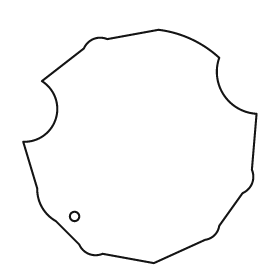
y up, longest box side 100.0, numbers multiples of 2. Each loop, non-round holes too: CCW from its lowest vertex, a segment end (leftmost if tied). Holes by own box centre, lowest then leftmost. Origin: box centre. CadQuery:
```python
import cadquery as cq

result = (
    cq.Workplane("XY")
    .moveTo(6.0, -50.0)
    .lineTo(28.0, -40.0)
    .threePointArc((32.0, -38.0), (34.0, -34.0))
    .lineTo(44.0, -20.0)
    .threePointArc((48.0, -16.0), (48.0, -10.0))
    .lineTo(50.0, 14.0)
    .threePointArc((36.0, 22.0), (34.0, 38.0))
    .threePointArc((22.0, 46.0), (8.0, 50.0))
    .lineTo(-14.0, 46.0)
    .threePointArc((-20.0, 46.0), (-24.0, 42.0))
    .lineTo(-42.0, 28.0)
    .threePointArc((-36.0, 12.0), (-50.0, 2.0))
    .lineTo(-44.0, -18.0)
    .threePointArc((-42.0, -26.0), (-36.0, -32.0))
    .lineTo(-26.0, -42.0)
    .threePointArc((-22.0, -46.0), (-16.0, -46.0))
    .close()
    .moveTo(-28.0, -30.0)
    .circle(2.0)
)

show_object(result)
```